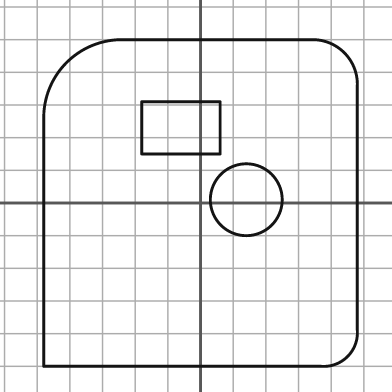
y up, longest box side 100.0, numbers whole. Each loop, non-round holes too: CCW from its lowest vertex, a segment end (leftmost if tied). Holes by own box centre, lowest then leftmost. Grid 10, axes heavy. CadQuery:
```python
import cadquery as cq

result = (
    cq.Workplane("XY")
    .moveTo(-48.0, -50.0)
    .lineTo(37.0, -50.0)
    .threePointArc((45.0, -47.0), (48.0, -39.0))
    .lineTo(48.0, 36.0)
    .threePointArc((44.0, 46.0), (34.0, 50.0))
    .lineTo(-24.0, 50.0)
    .threePointArc((-41.0, 43.0), (-48.0, 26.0))
    .close()
    .moveTo(14.0, 1.0)
    .circle(11.0)
    .moveTo(-18.0, 15.0)
    .lineTo(6.0, 15.0)
    .lineTo(6.0, 31.0)
    .lineTo(-18.0, 31.0)
    .close()
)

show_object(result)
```